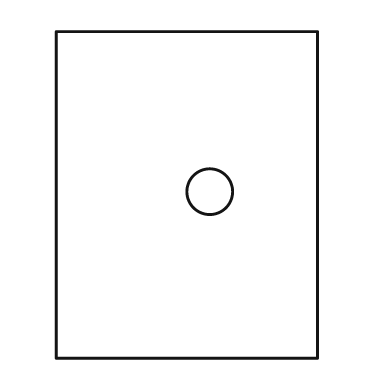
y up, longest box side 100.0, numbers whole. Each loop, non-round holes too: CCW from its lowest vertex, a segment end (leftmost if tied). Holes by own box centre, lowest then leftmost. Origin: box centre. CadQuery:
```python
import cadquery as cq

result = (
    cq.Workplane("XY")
    .moveTo(-40.0, -50.0)
    .lineTo(40.0, -50.0)
    .lineTo(40.0, 50.0)
    .lineTo(-40.0, 50.0)
    .close()
    .moveTo(7.0, 1.0)
    .circle(7.0)
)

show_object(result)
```